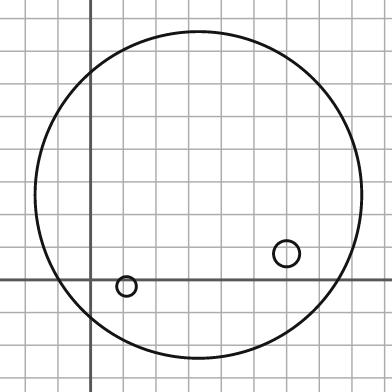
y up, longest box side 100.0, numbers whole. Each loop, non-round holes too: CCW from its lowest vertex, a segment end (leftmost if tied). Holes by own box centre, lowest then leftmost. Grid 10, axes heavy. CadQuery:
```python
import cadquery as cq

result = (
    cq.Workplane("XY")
    .moveTo(33.0, 26.0)
    .circle(50.0)
    .moveTo(11.0, -2.0)
    .circle(3.0)
    .moveTo(60.0, 8.0)
    .circle(4.0)
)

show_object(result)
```